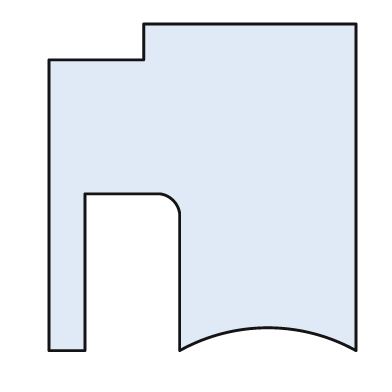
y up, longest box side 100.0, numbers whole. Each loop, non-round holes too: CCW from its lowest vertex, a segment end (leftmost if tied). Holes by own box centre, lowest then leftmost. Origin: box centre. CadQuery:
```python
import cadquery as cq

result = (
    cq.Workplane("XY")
    .moveTo(-47.0, -50.0)
    .lineTo(-36.0, -50.0)
    .lineTo(-36.0, -2.0)
    .lineTo(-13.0, -2.0)
    .threePointArc((-9.0, -4.0), (-7.0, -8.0))
    .lineTo(-7.0, -50.0)
    .threePointArc((20.0, -43.0), (47.0, -50.0))
    .lineTo(47.0, 50.0)
    .lineTo(-18.0, 50.0)
    .lineTo(-18.0, 39.0)
    .lineTo(-47.0, 39.0)
    .close()
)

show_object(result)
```